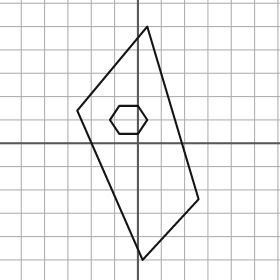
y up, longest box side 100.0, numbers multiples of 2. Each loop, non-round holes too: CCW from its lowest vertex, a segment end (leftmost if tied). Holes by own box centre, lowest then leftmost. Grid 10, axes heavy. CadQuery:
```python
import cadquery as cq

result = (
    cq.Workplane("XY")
    .moveTo(2.0, -50.0)
    .lineTo(26.0, -24.0)
    .lineTo(4.0, 50.0)
    .lineTo(-26.0, 14.0)
    .close()
    .moveTo(-8.0, 4.0)
    .lineTo(0.0, 4.0)
    .lineTo(4.0, 10.0)
    .lineTo(0.0, 16.0)
    .lineTo(-8.0, 16.0)
    .lineTo(-12.0, 10.0)
    .close()
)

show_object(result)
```